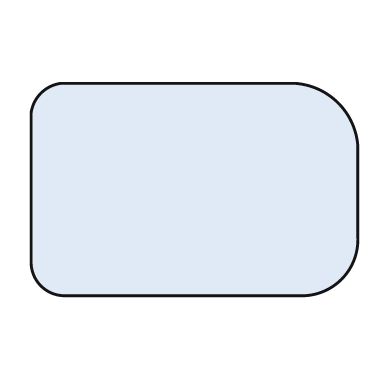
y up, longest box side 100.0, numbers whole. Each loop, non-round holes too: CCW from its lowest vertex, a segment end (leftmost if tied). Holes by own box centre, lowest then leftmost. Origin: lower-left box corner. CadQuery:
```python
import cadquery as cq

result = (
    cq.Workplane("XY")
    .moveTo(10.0, 0.0)
    .lineTo(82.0, 0.0)
    .threePointArc((95.0, 5.0), (100.0, 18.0))
    .lineTo(100.0, 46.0)
    .threePointArc((94.0, 59.0), (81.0, 65.0))
    .lineTo(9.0, 65.0)
    .threePointArc((3.0, 62.0), (0.0, 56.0))
    .lineTo(0.0, 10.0)
    .threePointArc((3.0, 3.0), (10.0, 0.0))
    .close()
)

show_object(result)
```